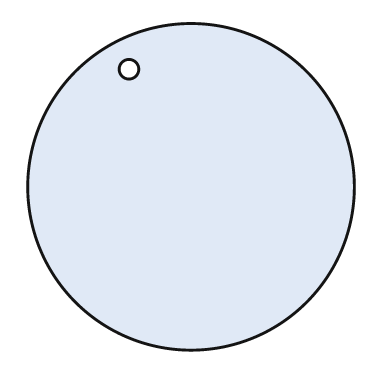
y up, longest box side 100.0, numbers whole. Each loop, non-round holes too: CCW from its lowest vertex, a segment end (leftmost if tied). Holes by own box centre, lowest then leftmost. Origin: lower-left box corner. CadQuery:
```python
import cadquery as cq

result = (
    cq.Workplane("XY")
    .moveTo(50.0, 50.0)
    .circle(50.0)
    .moveTo(31.0, 86.0)
    .circle(3.0)
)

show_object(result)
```